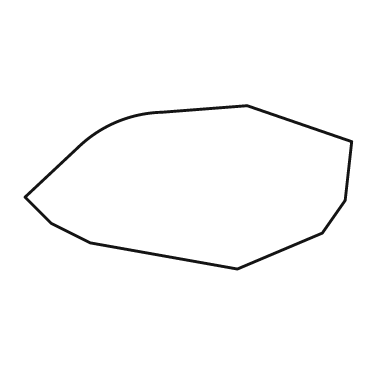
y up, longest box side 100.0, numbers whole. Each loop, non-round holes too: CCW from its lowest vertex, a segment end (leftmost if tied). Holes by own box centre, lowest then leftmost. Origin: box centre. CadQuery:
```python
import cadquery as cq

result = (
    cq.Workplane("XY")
    .moveTo(15.0, -25.0)
    .lineTo(41.0, -14.0)
    .lineTo(48.0, -4.0)
    .lineTo(50.0, 14.0)
    .lineTo(18.0, 25.0)
    .lineTo(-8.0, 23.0)
    .threePointArc((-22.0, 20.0), (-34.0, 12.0))
    .lineTo(-50.0, -3.0)
    .lineTo(-42.0, -11.0)
    .lineTo(-30.0, -17.0)
    .close()
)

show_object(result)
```